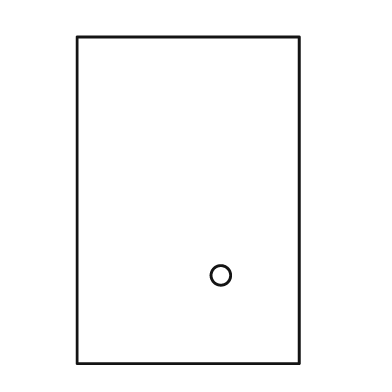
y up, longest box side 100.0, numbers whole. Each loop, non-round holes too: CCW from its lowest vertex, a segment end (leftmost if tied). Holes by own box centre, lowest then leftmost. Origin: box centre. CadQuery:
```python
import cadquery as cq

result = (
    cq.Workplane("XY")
    .moveTo(-34.0, -50.0)
    .lineTo(34.0, -50.0)
    .lineTo(34.0, 50.0)
    .lineTo(-34.0, 50.0)
    .close()
    .moveTo(10.0, -23.0)
    .circle(3.0)
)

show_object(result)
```